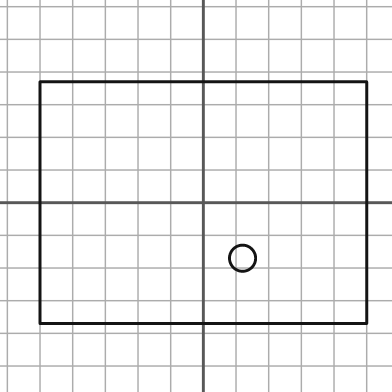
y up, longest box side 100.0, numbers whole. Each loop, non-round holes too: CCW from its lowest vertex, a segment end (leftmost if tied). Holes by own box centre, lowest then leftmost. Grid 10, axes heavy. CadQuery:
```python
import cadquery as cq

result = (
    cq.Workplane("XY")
    .moveTo(-50.0, -37.0)
    .lineTo(50.0, -37.0)
    .lineTo(50.0, 37.0)
    .lineTo(-50.0, 37.0)
    .close()
    .moveTo(12.0, -17.0)
    .circle(4.0)
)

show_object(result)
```